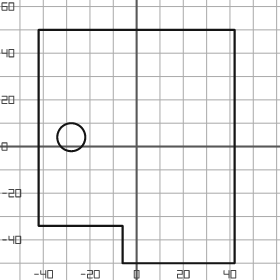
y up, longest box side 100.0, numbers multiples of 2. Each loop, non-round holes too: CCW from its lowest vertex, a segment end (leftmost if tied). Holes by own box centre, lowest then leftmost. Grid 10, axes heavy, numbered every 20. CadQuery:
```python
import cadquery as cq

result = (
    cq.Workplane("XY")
    .moveTo(-6.0, -50.0)
    .lineTo(42.0, -50.0)
    .lineTo(42.0, 50.0)
    .lineTo(-42.0, 50.0)
    .lineTo(-42.0, -34.0)
    .lineTo(-6.0, -34.0)
    .close()
    .moveTo(-28.0, 4.0)
    .circle(6.0)
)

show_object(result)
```